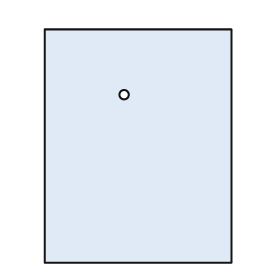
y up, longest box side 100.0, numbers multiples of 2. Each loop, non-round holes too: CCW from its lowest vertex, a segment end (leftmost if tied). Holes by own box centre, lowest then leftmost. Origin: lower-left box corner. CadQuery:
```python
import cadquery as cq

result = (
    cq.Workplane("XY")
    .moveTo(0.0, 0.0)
    .lineTo(80.0, 0.0)
    .lineTo(80.0, 100.0)
    .lineTo(0.0, 100.0)
    .close()
    .moveTo(34.0, 72.0)
    .circle(2.0)
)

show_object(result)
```